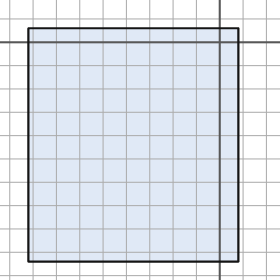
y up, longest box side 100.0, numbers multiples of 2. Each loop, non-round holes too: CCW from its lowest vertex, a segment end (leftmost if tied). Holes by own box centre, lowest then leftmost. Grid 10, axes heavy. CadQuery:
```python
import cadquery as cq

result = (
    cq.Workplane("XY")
    .moveTo(-82.0, -94.0)
    .lineTo(8.0, -94.0)
    .lineTo(8.0, 6.0)
    .lineTo(-82.0, 6.0)
    .close()
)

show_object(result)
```